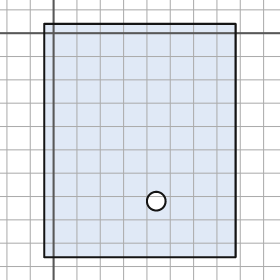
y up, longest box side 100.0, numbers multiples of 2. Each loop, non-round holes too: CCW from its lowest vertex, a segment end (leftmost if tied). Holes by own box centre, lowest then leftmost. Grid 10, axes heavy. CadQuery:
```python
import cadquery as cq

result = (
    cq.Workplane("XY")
    .moveTo(-4.0, -96.0)
    .lineTo(78.0, -96.0)
    .lineTo(78.0, 4.0)
    .lineTo(-4.0, 4.0)
    .close()
    .moveTo(44.0, -72.0)
    .circle(4.0)
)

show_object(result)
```